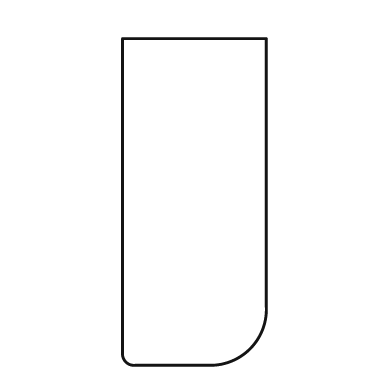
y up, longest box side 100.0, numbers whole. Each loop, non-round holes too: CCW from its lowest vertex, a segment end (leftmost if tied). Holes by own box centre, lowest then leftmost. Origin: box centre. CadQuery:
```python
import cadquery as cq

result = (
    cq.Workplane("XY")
    .moveTo(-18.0, -50.0)
    .lineTo(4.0, -50.0)
    .threePointArc((17.0, -45.0), (22.0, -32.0))
    .lineTo(22.0, 50.0)
    .lineTo(-22.0, 50.0)
    .lineTo(-22.0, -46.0)
    .threePointArc((-21.0, -49.0), (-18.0, -50.0))
    .close()
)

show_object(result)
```